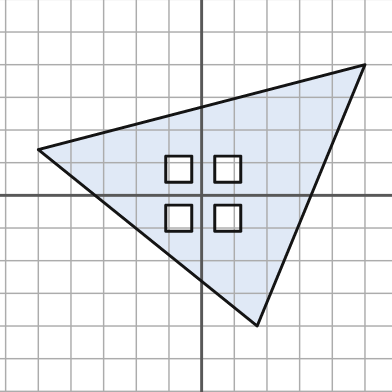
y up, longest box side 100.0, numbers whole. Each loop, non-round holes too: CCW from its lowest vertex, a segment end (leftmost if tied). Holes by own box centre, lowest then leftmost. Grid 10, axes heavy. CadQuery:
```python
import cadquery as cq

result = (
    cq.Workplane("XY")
    .moveTo(17.0, -40.0)
    .lineTo(50.0, 40.0)
    .lineTo(-50.0, 14.0)
    .close()
    .moveTo(-11.0, -11.0)
    .lineTo(-3.0, -11.0)
    .lineTo(-3.0, -3.0)
    .lineTo(-11.0, -3.0)
    .close()
    .moveTo(4.0, -11.0)
    .lineTo(12.0, -11.0)
    .lineTo(12.0, -3.0)
    .lineTo(4.0, -3.0)
    .close()
    .moveTo(-11.0, 4.0)
    .lineTo(-3.0, 4.0)
    .lineTo(-3.0, 12.0)
    .lineTo(-11.0, 12.0)
    .close()
    .moveTo(4.0, 4.0)
    .lineTo(12.0, 4.0)
    .lineTo(12.0, 12.0)
    .lineTo(4.0, 12.0)
    .close()
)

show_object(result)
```